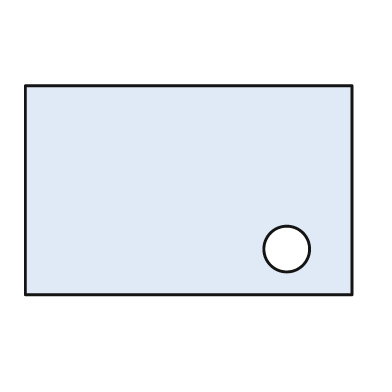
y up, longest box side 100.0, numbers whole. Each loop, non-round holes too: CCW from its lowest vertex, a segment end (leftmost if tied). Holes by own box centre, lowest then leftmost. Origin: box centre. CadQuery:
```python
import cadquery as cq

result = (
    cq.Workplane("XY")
    .moveTo(-50.0, -32.0)
    .lineTo(50.0, -32.0)
    .lineTo(50.0, 32.0)
    .lineTo(-50.0, 32.0)
    .close()
    .moveTo(30.0, -18.0)
    .circle(7.0)
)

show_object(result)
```